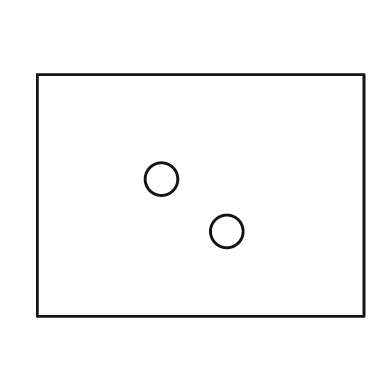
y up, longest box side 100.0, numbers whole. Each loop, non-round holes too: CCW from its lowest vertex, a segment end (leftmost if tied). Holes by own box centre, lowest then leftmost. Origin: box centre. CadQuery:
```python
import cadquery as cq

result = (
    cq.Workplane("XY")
    .moveTo(-50.0, -37.0)
    .lineTo(50.0, -37.0)
    .lineTo(50.0, 37.0)
    .lineTo(-50.0, 37.0)
    .close()
    .moveTo(8.0, -11.0)
    .circle(5.0)
    .moveTo(-12.0, 5.0)
    .circle(5.0)
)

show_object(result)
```